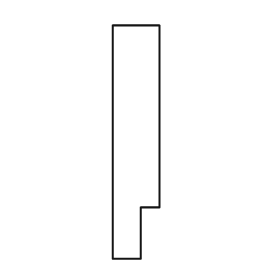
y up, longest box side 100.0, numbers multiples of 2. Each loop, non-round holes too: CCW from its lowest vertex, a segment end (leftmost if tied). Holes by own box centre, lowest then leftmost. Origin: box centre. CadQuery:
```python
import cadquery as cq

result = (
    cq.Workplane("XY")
    .moveTo(-10.0, -50.0)
    .lineTo(2.0, -50.0)
    .lineTo(2.0, -28.0)
    .lineTo(10.0, -28.0)
    .lineTo(10.0, 50.0)
    .lineTo(-10.0, 50.0)
    .close()
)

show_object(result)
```